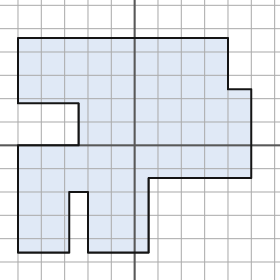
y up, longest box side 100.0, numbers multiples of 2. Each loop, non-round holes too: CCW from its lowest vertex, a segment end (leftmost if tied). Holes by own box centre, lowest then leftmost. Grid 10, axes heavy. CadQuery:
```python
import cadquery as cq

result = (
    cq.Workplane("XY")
    .moveTo(-50.0, -46.0)
    .lineTo(-28.0, -46.0)
    .lineTo(-28.0, -20.0)
    .lineTo(-20.0, -20.0)
    .lineTo(-20.0, -46.0)
    .lineTo(6.0, -46.0)
    .lineTo(6.0, -14.0)
    .lineTo(50.0, -14.0)
    .lineTo(50.0, 24.0)
    .lineTo(40.0, 24.0)
    .lineTo(40.0, 46.0)
    .lineTo(-50.0, 46.0)
    .lineTo(-50.0, 18.0)
    .lineTo(-24.0, 18.0)
    .lineTo(-24.0, 0.0)
    .lineTo(-50.0, 0.0)
    .close()
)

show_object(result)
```